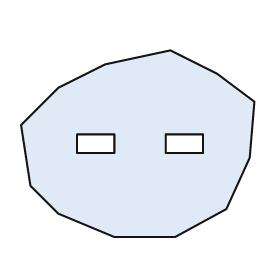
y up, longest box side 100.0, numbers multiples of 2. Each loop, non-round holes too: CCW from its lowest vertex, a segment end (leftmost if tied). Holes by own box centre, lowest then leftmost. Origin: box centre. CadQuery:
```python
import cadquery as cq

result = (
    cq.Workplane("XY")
    .moveTo(-10.0, -40.0)
    .lineTo(16.0, -40.0)
    .lineTo(38.0, -28.0)
    .lineTo(48.0, -6.0)
    .lineTo(50.0, 18.0)
    .lineTo(34.0, 30.0)
    .lineTo(14.0, 40.0)
    .lineTo(-14.0, 34.0)
    .lineTo(-34.0, 24.0)
    .lineTo(-50.0, 8.0)
    .lineTo(-46.0, -18.0)
    .lineTo(-34.0, -30.0)
    .close()
    .moveTo(-26.0, -4.0)
    .lineTo(-10.0, -4.0)
    .lineTo(-10.0, 4.0)
    .lineTo(-26.0, 4.0)
    .close()
    .moveTo(12.0, -4.0)
    .lineTo(28.0, -4.0)
    .lineTo(28.0, 4.0)
    .lineTo(12.0, 4.0)
    .close()
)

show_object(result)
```